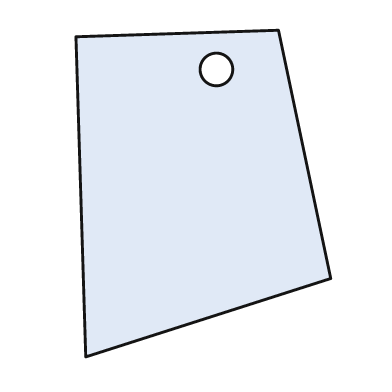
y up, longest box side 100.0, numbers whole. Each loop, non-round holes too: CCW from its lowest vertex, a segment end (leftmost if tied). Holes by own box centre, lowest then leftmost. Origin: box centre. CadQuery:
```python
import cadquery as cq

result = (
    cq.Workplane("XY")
    .moveTo(-36.0, -50.0)
    .lineTo(39.0, -26.0)
    .lineTo(23.0, 50.0)
    .lineTo(-39.0, 48.0)
    .close()
    .moveTo(4.0, 38.0)
    .circle(5.0)
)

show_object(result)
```